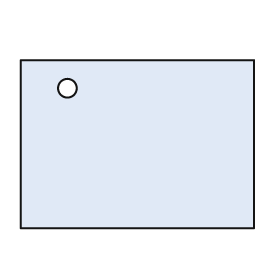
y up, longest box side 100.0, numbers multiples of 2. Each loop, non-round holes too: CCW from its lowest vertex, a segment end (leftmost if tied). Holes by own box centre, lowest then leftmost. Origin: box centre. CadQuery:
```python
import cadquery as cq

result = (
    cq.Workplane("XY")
    .moveTo(-50.0, -36.0)
    .lineTo(50.0, -36.0)
    .lineTo(50.0, 36.0)
    .lineTo(-50.0, 36.0)
    .close()
    .moveTo(-30.0, 24.0)
    .circle(4.0)
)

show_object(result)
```